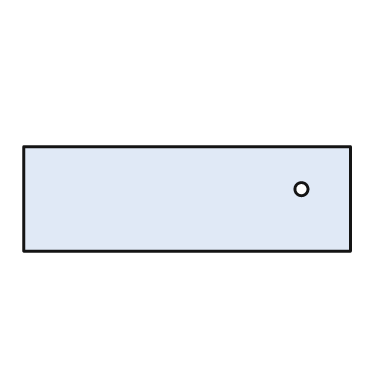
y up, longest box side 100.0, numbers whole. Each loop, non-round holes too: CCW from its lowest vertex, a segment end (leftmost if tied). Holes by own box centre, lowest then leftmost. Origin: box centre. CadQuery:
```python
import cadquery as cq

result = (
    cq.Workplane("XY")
    .moveTo(-50.0, -16.0)
    .lineTo(50.0, -16.0)
    .lineTo(50.0, 16.0)
    .lineTo(-50.0, 16.0)
    .close()
    .moveTo(35.0, 3.0)
    .circle(2.0)
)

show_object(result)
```